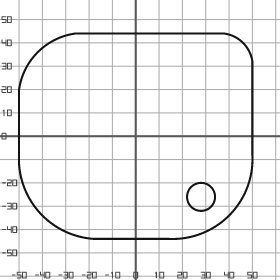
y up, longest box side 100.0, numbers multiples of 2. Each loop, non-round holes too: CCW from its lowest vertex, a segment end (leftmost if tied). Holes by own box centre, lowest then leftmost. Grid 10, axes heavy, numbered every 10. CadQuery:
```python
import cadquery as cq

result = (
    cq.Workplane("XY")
    .moveTo(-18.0, -44.0)
    .lineTo(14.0, -44.0)
    .threePointArc((40.0, -34.0), (50.0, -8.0))
    .lineTo(50.0, 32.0)
    .threePointArc((46.0, 40.0), (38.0, 44.0))
    .lineTo(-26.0, 44.0)
    .threePointArc((-42.0, 36.0), (-50.0, 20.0))
    .lineTo(-50.0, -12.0)
    .threePointArc((-40.0, -34.0), (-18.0, -44.0))
    .close()
    .moveTo(28.0, -26.0)
    .circle(6.0)
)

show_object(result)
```